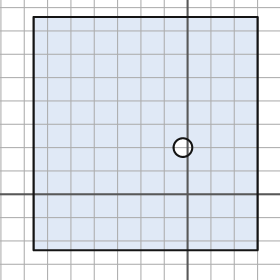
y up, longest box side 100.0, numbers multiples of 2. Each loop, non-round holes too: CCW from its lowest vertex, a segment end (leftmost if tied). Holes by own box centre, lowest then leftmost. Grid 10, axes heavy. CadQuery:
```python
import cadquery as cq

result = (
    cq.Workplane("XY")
    .moveTo(-66.0, -24.0)
    .lineTo(30.0, -24.0)
    .lineTo(30.0, 76.0)
    .lineTo(-66.0, 76.0)
    .close()
    .moveTo(-2.0, 20.0)
    .circle(4.0)
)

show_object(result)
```